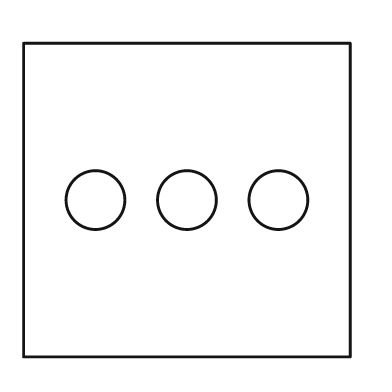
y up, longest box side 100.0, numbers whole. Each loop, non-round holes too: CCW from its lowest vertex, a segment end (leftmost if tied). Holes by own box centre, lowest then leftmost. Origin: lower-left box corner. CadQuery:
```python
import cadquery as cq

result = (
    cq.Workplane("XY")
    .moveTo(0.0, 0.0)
    .lineTo(100.0, 0.0)
    .lineTo(100.0, 96.0)
    .lineTo(0.0, 96.0)
    .close()
    .moveTo(22.0, 48.0)
    .circle(9.0)
    .moveTo(50.0, 48.0)
    .circle(9.0)
    .moveTo(78.0, 48.0)
    .circle(9.0)
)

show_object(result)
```